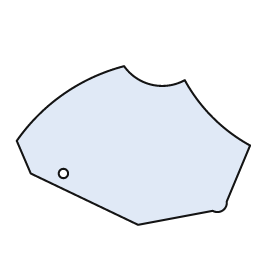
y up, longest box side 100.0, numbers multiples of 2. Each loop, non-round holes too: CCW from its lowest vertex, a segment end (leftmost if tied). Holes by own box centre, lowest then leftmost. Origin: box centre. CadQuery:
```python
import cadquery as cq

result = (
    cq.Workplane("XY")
    .moveTo(2.0, -34.0)
    .lineTo(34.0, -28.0)
    .threePointArc((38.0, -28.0), (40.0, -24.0))
    .lineTo(50.0, 0.0)
    .threePointArc((34.0, 12.0), (22.0, 28.0))
    .threePointArc((8.0, 26.0), (-4.0, 34.0))
    .threePointArc((-30.0, 22.0), (-50.0, 2.0))
    .lineTo(-44.0, -12.0)
    .close()
    .moveTo(-30.0, -12.0)
    .circle(2.0)
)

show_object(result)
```